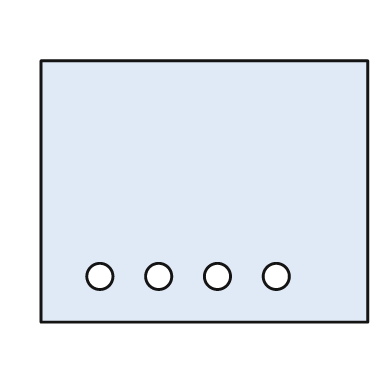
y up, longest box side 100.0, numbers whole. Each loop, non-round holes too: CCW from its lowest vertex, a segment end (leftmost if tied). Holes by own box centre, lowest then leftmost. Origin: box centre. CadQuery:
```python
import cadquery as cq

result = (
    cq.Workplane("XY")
    .moveTo(-50.0, -40.0)
    .lineTo(50.0, -40.0)
    .lineTo(50.0, 40.0)
    .lineTo(-50.0, 40.0)
    .close()
    .moveTo(-32.0, -26.0)
    .circle(4.0)
    .moveTo(-14.0, -26.0)
    .circle(4.0)
    .moveTo(4.0, -26.0)
    .circle(4.0)
    .moveTo(22.0, -26.0)
    .circle(4.0)
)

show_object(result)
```